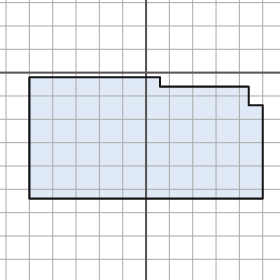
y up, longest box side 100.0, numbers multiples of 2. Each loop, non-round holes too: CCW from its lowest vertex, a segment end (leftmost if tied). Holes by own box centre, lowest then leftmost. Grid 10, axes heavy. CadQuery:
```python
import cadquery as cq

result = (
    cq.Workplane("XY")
    .moveTo(-50.0, -54.0)
    .lineTo(50.0, -54.0)
    .lineTo(50.0, -14.0)
    .lineTo(44.0, -14.0)
    .lineTo(44.0, -6.0)
    .lineTo(6.0, -6.0)
    .lineTo(6.0, -2.0)
    .lineTo(-50.0, -2.0)
    .close()
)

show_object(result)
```